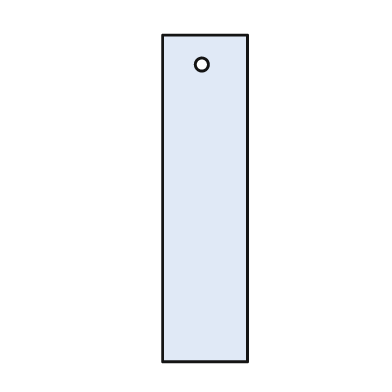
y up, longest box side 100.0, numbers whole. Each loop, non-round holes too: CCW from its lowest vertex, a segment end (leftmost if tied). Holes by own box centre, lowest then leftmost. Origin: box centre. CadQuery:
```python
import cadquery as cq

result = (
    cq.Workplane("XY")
    .moveTo(-13.0, -50.0)
    .lineTo(13.0, -50.0)
    .lineTo(13.0, 50.0)
    .lineTo(-13.0, 50.0)
    .close()
    .moveTo(-1.0, 41.0)
    .circle(2.0)
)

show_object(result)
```